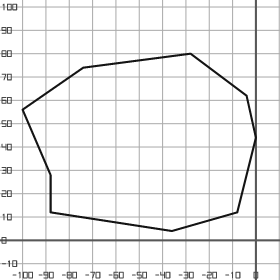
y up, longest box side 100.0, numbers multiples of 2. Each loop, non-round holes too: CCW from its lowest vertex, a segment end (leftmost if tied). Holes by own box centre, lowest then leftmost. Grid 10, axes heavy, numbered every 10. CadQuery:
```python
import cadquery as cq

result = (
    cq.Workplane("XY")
    .moveTo(-36.0, 4.0)
    .lineTo(-8.0, 12.0)
    .lineTo(0.0, 44.0)
    .lineTo(-4.0, 62.0)
    .lineTo(-28.0, 80.0)
    .lineTo(-74.0, 74.0)
    .lineTo(-100.0, 56.0)
    .lineTo(-88.0, 28.0)
    .lineTo(-88.0, 12.0)
    .close()
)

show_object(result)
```